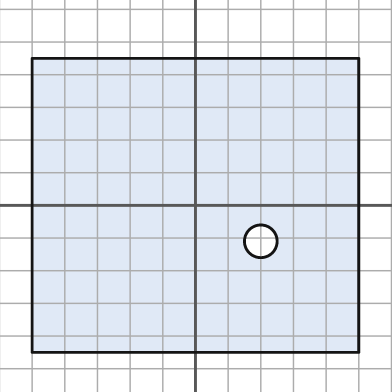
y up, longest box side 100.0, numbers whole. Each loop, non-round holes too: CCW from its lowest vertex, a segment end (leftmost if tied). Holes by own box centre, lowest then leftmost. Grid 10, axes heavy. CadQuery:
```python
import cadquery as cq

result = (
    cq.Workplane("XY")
    .moveTo(-50.0, -45.0)
    .lineTo(50.0, -45.0)
    .lineTo(50.0, 45.0)
    .lineTo(-50.0, 45.0)
    .close()
    .moveTo(20.0, -11.0)
    .circle(5.0)
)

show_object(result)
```